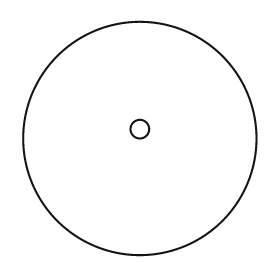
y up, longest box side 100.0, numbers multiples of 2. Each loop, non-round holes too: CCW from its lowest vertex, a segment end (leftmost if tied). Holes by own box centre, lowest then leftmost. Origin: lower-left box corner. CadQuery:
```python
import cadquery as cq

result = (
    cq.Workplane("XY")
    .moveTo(50.0, 50.0)
    .circle(50.0)
    .moveTo(50.0, 54.0)
    .circle(4.0)
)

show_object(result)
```